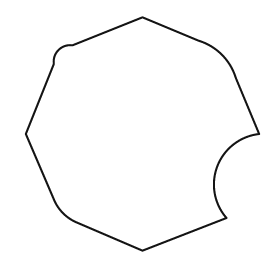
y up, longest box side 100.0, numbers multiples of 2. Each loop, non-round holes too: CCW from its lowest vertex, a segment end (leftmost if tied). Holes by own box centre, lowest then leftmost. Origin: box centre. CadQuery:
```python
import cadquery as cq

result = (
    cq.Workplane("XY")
    .moveTo(0.0, -50.0)
    .lineTo(36.0, -36.0)
    .threePointArc((32.0, -14.0), (50.0, 0.0))
    .lineTo(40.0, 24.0)
    .threePointArc((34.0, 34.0), (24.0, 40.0))
    .lineTo(0.0, 50.0)
    .lineTo(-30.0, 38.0)
    .threePointArc((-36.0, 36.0), (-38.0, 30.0))
    .lineTo(-50.0, 0.0)
    .lineTo(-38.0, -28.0)
    .threePointArc((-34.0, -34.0), (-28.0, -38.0))
    .close()
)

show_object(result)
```